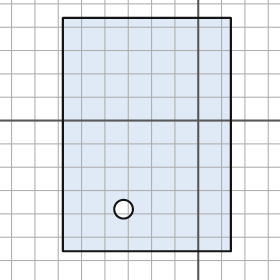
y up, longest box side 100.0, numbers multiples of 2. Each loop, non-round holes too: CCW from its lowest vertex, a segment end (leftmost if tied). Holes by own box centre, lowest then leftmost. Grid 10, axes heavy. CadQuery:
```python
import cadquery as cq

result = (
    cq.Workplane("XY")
    .moveTo(-58.0, -56.0)
    .lineTo(14.0, -56.0)
    .lineTo(14.0, 44.0)
    .lineTo(-58.0, 44.0)
    .close()
    .moveTo(-32.0, -38.0)
    .circle(4.0)
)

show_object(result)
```